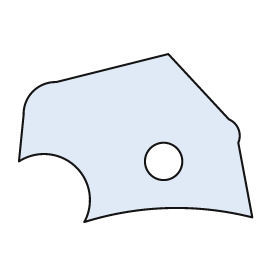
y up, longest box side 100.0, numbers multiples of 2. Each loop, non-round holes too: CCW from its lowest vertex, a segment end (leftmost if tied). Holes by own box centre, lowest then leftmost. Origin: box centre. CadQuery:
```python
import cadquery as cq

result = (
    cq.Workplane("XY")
    .moveTo(-22.0, -36.0)
    .threePointArc((14.0, -30.0), (50.0, -34.0))
    .lineTo(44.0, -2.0)
    .threePointArc((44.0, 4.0), (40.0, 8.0))
    .lineTo(14.0, 36.0)
    .lineTo(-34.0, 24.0)
    .threePointArc((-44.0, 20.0), (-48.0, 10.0))
    .lineTo(-50.0, -10.0)
    .threePointArc((-26.0, -12.0), (-22.0, -36.0))
    .close()
    .moveTo(12.0, -10.0)
    .circle(8.0)
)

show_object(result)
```